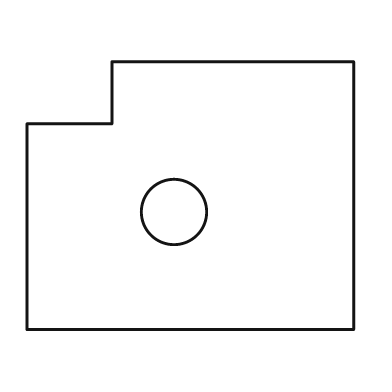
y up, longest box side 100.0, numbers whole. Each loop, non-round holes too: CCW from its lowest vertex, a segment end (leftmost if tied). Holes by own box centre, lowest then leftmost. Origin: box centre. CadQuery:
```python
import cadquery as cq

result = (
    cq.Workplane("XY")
    .moveTo(-50.0, -41.0)
    .lineTo(50.0, -41.0)
    .lineTo(50.0, 41.0)
    .lineTo(-24.0, 41.0)
    .lineTo(-24.0, 22.0)
    .lineTo(-50.0, 22.0)
    .close()
    .moveTo(-5.0, -5.0)
    .circle(10.0)
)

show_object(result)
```